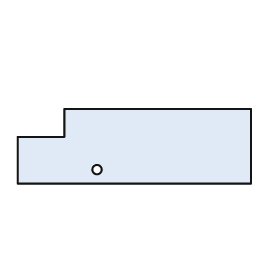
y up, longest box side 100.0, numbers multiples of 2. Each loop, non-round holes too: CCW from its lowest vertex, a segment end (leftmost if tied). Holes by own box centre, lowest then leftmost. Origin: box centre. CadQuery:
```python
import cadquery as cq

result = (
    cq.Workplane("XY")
    .moveTo(-50.0, -16.0)
    .lineTo(50.0, -16.0)
    .lineTo(50.0, 16.0)
    .lineTo(-30.0, 16.0)
    .lineTo(-30.0, 4.0)
    .lineTo(-50.0, 4.0)
    .close()
    .moveTo(-16.0, -10.0)
    .circle(2.0)
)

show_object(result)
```